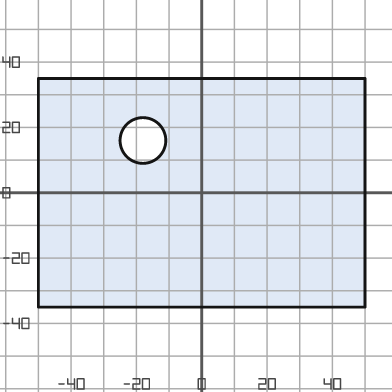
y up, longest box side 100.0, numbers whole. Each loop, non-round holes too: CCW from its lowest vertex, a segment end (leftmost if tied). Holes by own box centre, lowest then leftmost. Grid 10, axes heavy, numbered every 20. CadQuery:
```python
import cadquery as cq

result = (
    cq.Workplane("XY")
    .moveTo(-50.0, -35.0)
    .lineTo(50.0, -35.0)
    .lineTo(50.0, 35.0)
    .lineTo(-50.0, 35.0)
    .close()
    .moveTo(-18.0, 16.0)
    .circle(7.0)
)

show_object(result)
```